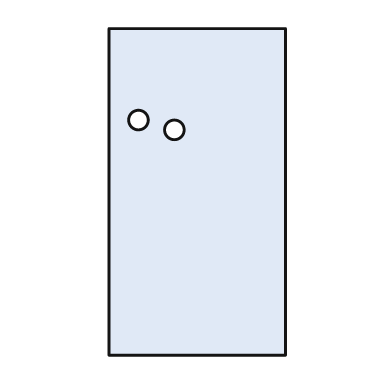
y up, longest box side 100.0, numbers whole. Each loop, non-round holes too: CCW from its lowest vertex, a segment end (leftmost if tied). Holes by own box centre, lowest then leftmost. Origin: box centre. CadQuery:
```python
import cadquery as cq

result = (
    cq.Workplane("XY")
    .moveTo(-27.0, -50.0)
    .lineTo(27.0, -50.0)
    .lineTo(27.0, 50.0)
    .lineTo(-27.0, 50.0)
    .close()
    .moveTo(-7.0, 19.0)
    .circle(3.0)
    .moveTo(-18.0, 22.0)
    .circle(3.0)
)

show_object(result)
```